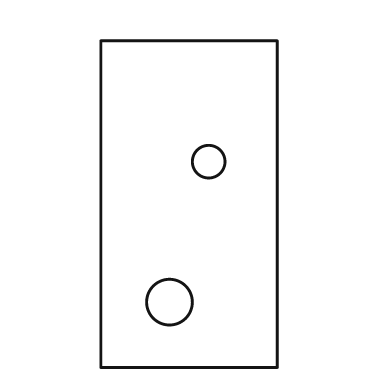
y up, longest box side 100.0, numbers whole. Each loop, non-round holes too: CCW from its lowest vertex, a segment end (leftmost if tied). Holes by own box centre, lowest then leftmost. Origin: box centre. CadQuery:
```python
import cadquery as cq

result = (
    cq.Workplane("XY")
    .moveTo(-27.0, -50.0)
    .lineTo(27.0, -50.0)
    .lineTo(27.0, 50.0)
    .lineTo(-27.0, 50.0)
    .close()
    .moveTo(-6.0, -30.0)
    .circle(7.0)
    .moveTo(6.0, 13.0)
    .circle(5.0)
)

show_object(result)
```